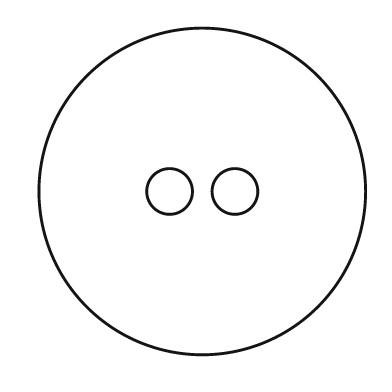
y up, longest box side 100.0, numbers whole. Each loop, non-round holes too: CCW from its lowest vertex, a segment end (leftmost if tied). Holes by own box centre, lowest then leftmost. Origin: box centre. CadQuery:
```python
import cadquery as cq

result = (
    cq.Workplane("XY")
    .moveTo(0.0, 0.0)
    .circle(50.0)
    .moveTo(-10.0, 0.0)
    .circle(7.0)
    .moveTo(10.0, 0.0)
    .circle(7.0)
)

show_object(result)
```